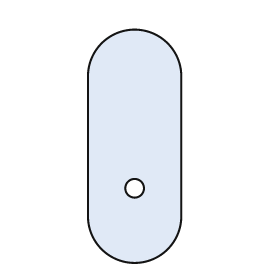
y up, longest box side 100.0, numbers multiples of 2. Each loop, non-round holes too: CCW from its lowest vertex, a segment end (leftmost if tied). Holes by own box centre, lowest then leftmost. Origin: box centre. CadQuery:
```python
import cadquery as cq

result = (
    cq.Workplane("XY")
    .moveTo(-20.0, -30.0)
    .threePointArc((0.0, -50.0), (20.0, -30.0))
    .lineTo(20.0, 30.0)
    .threePointArc((0.0, 50.0), (-20.0, 30.0))
    .close()
    .moveTo(0.0, -18.0)
    .circle(4.0)
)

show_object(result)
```